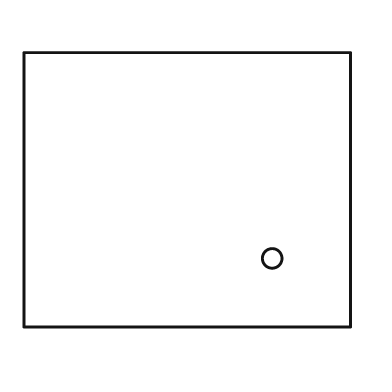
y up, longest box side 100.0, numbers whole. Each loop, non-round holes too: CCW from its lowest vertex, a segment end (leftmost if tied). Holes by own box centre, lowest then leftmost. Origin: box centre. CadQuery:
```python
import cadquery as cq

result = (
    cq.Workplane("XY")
    .moveTo(-50.0, -42.0)
    .lineTo(50.0, -42.0)
    .lineTo(50.0, 42.0)
    .lineTo(-50.0, 42.0)
    .close()
    .moveTo(26.0, -21.0)
    .circle(3.0)
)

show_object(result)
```